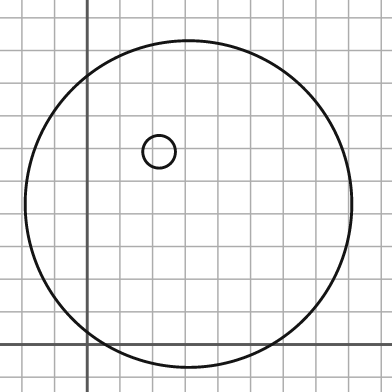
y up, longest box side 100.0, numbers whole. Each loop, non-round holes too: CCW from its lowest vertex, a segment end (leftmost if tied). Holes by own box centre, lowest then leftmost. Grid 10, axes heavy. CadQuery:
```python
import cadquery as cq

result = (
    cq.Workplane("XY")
    .moveTo(31.0, 43.0)
    .circle(50.0)
    .moveTo(22.0, 59.0)
    .circle(5.0)
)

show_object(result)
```